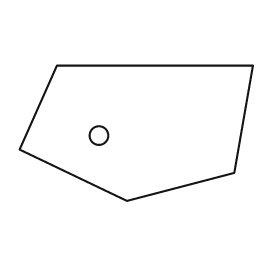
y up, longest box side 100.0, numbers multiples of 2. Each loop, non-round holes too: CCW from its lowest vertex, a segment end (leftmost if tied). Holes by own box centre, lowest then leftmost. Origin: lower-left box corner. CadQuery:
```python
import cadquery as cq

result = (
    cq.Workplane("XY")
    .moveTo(46.0, 0.0)
    .lineTo(92.0, 12.0)
    .lineTo(100.0, 58.0)
    .lineTo(16.0, 58.0)
    .lineTo(0.0, 22.0)
    .close()
    .moveTo(34.0, 28.0)
    .circle(4.0)
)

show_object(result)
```